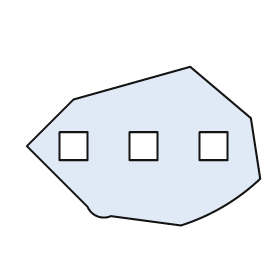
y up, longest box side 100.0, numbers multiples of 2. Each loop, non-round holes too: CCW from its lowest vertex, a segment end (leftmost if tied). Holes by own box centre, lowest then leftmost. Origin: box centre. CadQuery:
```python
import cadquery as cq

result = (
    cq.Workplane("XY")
    .moveTo(16.0, -34.0)
    .threePointArc((34.0, -26.0), (50.0, -14.0))
    .lineTo(46.0, 12.0)
    .lineTo(20.0, 34.0)
    .lineTo(-30.0, 20.0)
    .lineTo(-50.0, 0.0)
    .lineTo(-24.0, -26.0)
    .threePointArc((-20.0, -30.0), (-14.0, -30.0))
    .close()
    .moveTo(-36.0, -6.0)
    .lineTo(-24.0, -6.0)
    .lineTo(-24.0, 6.0)
    .lineTo(-36.0, 6.0)
    .close()
    .moveTo(-6.0, -6.0)
    .lineTo(6.0, -6.0)
    .lineTo(6.0, 6.0)
    .lineTo(-6.0, 6.0)
    .close()
    .moveTo(24.0, -6.0)
    .lineTo(36.0, -6.0)
    .lineTo(36.0, 6.0)
    .lineTo(24.0, 6.0)
    .close()
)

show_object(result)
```